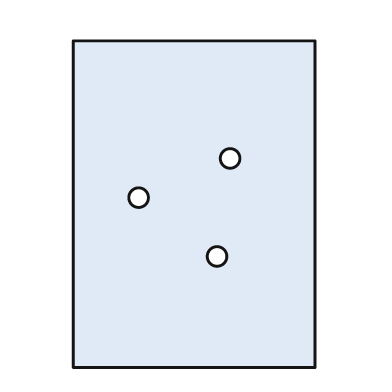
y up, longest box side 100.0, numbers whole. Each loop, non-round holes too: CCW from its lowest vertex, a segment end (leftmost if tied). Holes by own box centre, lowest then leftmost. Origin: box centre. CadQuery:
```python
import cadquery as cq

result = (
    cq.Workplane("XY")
    .moveTo(-37.0, -50.0)
    .lineTo(37.0, -50.0)
    .lineTo(37.0, 50.0)
    .lineTo(-37.0, 50.0)
    .close()
    .moveTo(7.0, -16.0)
    .circle(3.0)
    .moveTo(-17.0, 2.0)
    .circle(3.0)
    .moveTo(11.0, 14.0)
    .circle(3.0)
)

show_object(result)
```